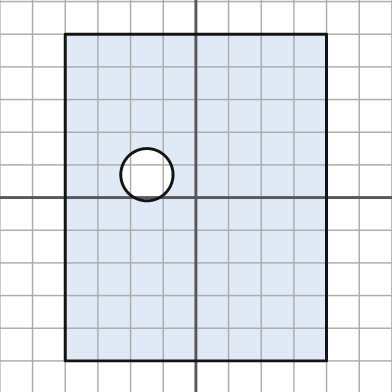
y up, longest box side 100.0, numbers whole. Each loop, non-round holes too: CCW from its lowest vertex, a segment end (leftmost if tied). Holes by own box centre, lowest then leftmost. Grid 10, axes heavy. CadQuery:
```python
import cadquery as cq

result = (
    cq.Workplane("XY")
    .moveTo(-40.0, -50.0)
    .lineTo(40.0, -50.0)
    .lineTo(40.0, 50.0)
    .lineTo(-40.0, 50.0)
    .close()
    .moveTo(-15.0, 7.0)
    .circle(8.0)
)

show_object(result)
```